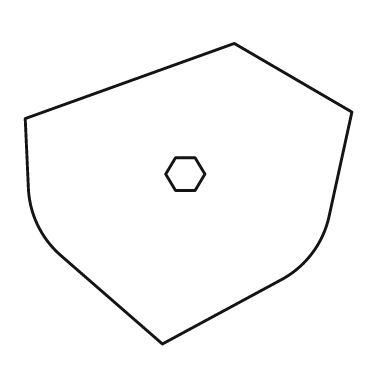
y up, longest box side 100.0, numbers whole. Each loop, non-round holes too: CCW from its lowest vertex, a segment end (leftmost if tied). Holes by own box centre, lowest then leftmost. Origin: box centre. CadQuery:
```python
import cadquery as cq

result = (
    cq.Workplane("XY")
    .moveTo(-8.0, -46.0)
    .lineTo(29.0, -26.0)
    .threePointArc((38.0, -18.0), (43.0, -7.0))
    .lineTo(50.0, 25.0)
    .lineTo(14.0, 46.0)
    .lineTo(-50.0, 23.0)
    .lineTo(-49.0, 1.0)
    .threePointArc((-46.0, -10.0), (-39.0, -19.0))
    .close()
    .moveTo(-4.0, 1.0)
    .lineTo(2.0, 1.0)
    .lineTo(5.0, 6.0)
    .lineTo(2.0, 11.0)
    .lineTo(-4.0, 11.0)
    .lineTo(-7.0, 6.0)
    .close()
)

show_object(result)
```